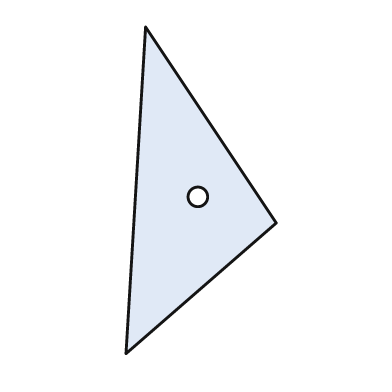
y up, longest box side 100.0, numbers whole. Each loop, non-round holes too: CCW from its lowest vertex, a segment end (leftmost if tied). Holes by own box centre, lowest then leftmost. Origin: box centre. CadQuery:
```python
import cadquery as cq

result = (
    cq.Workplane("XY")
    .moveTo(-23.0, -50.0)
    .lineTo(23.0, -10.0)
    .lineTo(-17.0, 50.0)
    .close()
    .moveTo(-1.0, -2.0)
    .circle(3.0)
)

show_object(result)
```